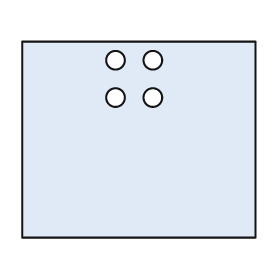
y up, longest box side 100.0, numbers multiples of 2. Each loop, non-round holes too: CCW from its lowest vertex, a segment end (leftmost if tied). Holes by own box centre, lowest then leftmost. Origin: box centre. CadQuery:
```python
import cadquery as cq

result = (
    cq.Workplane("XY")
    .moveTo(-50.0, -42.0)
    .lineTo(50.0, -42.0)
    .lineTo(50.0, 42.0)
    .lineTo(-50.0, 42.0)
    .close()
    .moveTo(-10.0, 18.0)
    .circle(4.0)
    .moveTo(6.0, 18.0)
    .circle(4.0)
    .moveTo(-10.0, 34.0)
    .circle(4.0)
    .moveTo(6.0, 34.0)
    .circle(4.0)
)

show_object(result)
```